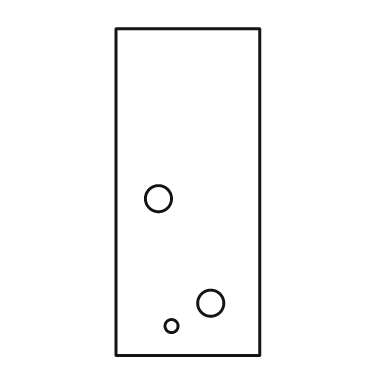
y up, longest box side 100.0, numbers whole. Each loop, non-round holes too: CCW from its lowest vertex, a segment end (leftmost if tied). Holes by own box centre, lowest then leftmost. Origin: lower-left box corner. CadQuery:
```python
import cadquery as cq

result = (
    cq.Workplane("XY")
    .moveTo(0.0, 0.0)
    .lineTo(44.0, 0.0)
    .lineTo(44.0, 100.0)
    .lineTo(0.0, 100.0)
    .close()
    .moveTo(17.0, 9.0)
    .circle(2.0)
    .moveTo(29.0, 16.0)
    .circle(4.0)
    .moveTo(13.0, 48.0)
    .circle(4.0)
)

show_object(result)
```